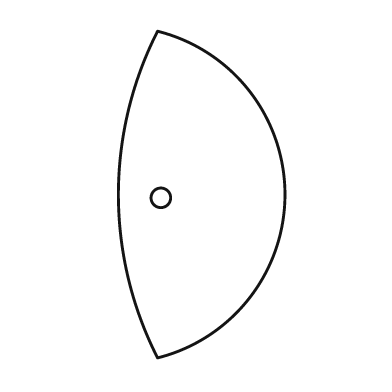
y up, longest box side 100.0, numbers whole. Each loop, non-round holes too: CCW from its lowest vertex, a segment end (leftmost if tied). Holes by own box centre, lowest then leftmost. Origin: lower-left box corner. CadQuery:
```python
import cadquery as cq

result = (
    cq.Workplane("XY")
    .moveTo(12.0, 0.0)
    .threePointArc((51.0, 50.0), (12.0, 100.0))
    .threePointArc((0.0, 50.0), (12.0, 0.0))
    .close()
    .moveTo(13.0, 49.0)
    .circle(3.0)
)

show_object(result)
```